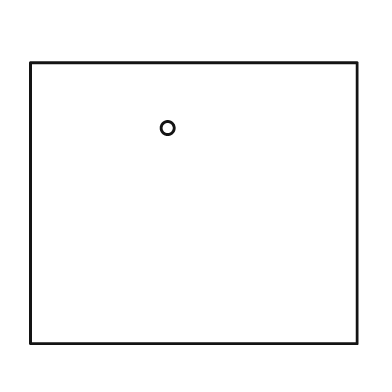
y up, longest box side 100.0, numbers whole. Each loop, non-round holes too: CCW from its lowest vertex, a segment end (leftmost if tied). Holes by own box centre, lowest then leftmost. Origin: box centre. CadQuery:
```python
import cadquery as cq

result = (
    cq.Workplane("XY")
    .moveTo(-50.0, -43.0)
    .lineTo(50.0, -43.0)
    .lineTo(50.0, 43.0)
    .lineTo(-50.0, 43.0)
    .close()
    .moveTo(-8.0, 23.0)
    .circle(2.0)
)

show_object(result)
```